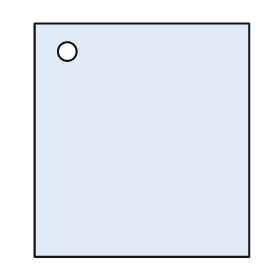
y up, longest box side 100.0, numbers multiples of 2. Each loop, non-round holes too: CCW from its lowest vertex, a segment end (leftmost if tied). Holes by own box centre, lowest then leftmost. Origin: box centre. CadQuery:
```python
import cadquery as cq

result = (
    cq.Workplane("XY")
    .moveTo(-46.0, -50.0)
    .lineTo(46.0, -50.0)
    .lineTo(46.0, 50.0)
    .lineTo(-46.0, 50.0)
    .close()
    .moveTo(-32.0, 38.0)
    .circle(4.0)
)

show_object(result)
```